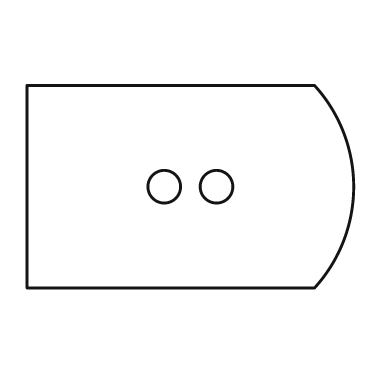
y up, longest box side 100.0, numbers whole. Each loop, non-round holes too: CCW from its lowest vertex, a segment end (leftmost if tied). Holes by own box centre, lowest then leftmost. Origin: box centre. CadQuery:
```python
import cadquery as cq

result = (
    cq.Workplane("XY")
    .moveTo(-50.0, -31.0)
    .lineTo(38.0, -31.0)
    .threePointArc((50.0, 0.0), (38.0, 31.0))
    .lineTo(-50.0, 31.0)
    .close()
    .moveTo(-8.0, 0.0)
    .circle(5.0)
    .moveTo(8.0, 0.0)
    .circle(5.0)
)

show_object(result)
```